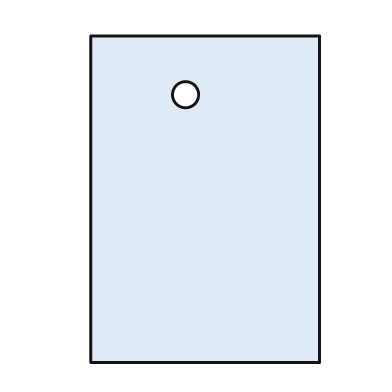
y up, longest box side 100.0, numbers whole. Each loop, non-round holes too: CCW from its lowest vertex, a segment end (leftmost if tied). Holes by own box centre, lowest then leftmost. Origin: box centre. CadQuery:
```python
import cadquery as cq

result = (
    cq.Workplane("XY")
    .moveTo(-35.0, -50.0)
    .lineTo(35.0, -50.0)
    .lineTo(35.0, 50.0)
    .lineTo(-35.0, 50.0)
    .close()
    .moveTo(-6.0, 32.0)
    .circle(4.0)
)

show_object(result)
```